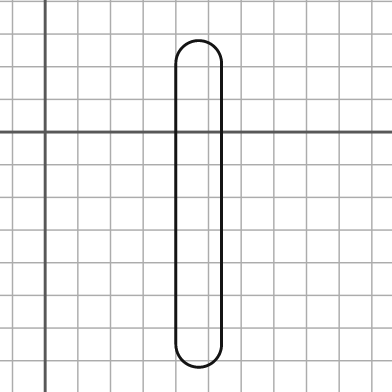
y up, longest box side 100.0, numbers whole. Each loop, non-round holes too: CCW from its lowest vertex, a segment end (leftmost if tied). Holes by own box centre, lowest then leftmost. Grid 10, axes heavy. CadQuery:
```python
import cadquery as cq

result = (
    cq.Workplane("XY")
    .moveTo(40.0, -65.0)
    .threePointArc((47.0, -72.0), (54.0, -65.0))
    .lineTo(54.0, 21.0)
    .threePointArc((47.0, 28.0), (40.0, 21.0))
    .close()
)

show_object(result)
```